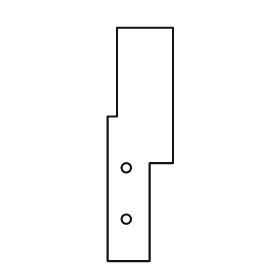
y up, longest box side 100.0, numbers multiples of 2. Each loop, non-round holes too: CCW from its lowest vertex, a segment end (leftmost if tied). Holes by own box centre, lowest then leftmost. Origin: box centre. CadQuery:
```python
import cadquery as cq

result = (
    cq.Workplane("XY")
    .moveTo(-14.0, -50.0)
    .lineTo(4.0, -50.0)
    .lineTo(4.0, -8.0)
    .lineTo(14.0, -8.0)
    .lineTo(14.0, 50.0)
    .lineTo(-10.0, 50.0)
    .lineTo(-10.0, 12.0)
    .lineTo(-14.0, 12.0)
    .close()
    .moveTo(-6.0, -32.0)
    .circle(2.0)
    .moveTo(-6.0, -10.0)
    .circle(2.0)
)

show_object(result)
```